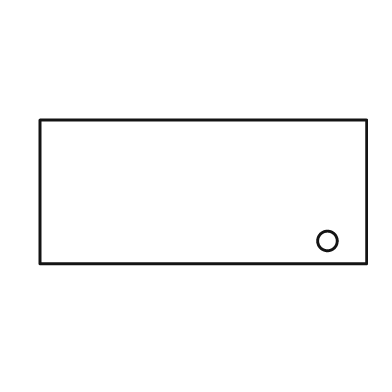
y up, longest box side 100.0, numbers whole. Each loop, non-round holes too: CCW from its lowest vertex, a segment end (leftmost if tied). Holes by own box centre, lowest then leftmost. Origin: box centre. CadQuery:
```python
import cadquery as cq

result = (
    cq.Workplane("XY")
    .moveTo(-50.0, -22.0)
    .lineTo(50.0, -22.0)
    .lineTo(50.0, 22.0)
    .lineTo(-50.0, 22.0)
    .close()
    .moveTo(38.0, -15.0)
    .circle(3.0)
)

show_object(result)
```